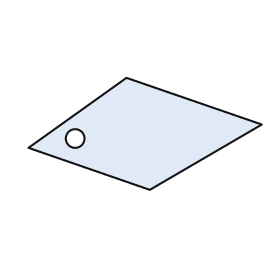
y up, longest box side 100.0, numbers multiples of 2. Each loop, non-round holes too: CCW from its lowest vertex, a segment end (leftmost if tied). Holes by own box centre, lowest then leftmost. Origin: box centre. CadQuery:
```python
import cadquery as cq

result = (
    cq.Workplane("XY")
    .moveTo(2.0, -24.0)
    .lineTo(50.0, 4.0)
    .lineTo(-8.0, 24.0)
    .lineTo(-50.0, -6.0)
    .close()
    .moveTo(-30.0, -2.0)
    .circle(4.0)
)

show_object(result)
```